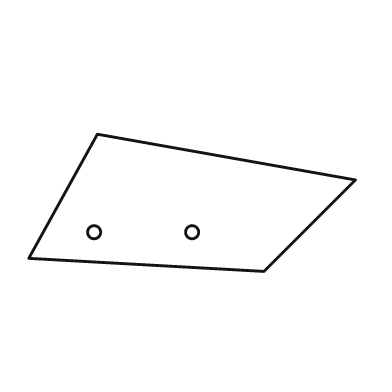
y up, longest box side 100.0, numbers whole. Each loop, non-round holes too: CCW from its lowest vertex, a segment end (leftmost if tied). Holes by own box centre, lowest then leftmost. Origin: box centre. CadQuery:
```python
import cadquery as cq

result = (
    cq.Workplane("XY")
    .moveTo(22.0, -21.0)
    .lineTo(50.0, 7.0)
    .lineTo(-29.0, 21.0)
    .lineTo(-50.0, -17.0)
    .close()
    .moveTo(-30.0, -9.0)
    .circle(2.0)
    .moveTo(0.0, -9.0)
    .circle(2.0)
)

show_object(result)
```